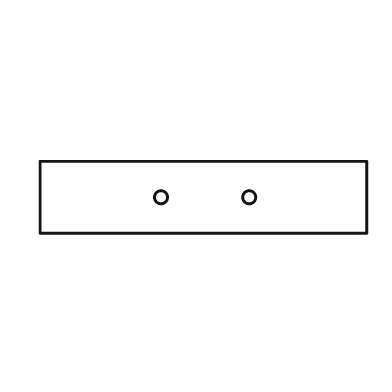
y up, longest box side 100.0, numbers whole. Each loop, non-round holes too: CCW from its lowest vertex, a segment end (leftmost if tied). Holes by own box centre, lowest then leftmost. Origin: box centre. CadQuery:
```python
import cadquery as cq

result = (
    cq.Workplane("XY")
    .moveTo(-50.0, -11.0)
    .lineTo(50.0, -11.0)
    .lineTo(50.0, 11.0)
    .lineTo(-50.0, 11.0)
    .close()
    .moveTo(-13.0, 0.0)
    .circle(2.0)
    .moveTo(14.0, 0.0)
    .circle(2.0)
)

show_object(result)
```